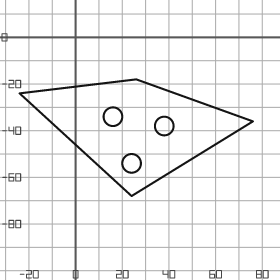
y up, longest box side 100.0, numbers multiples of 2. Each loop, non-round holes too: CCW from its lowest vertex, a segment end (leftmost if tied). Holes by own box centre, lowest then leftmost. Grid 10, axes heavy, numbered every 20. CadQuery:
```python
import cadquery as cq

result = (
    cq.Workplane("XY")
    .moveTo(24.0, -68.0)
    .lineTo(76.0, -36.0)
    .lineTo(26.0, -18.0)
    .lineTo(-24.0, -24.0)
    .close()
    .moveTo(24.0, -54.0)
    .circle(4.0)
    .moveTo(38.0, -38.0)
    .circle(4.0)
    .moveTo(16.0, -34.0)
    .circle(4.0)
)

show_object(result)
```